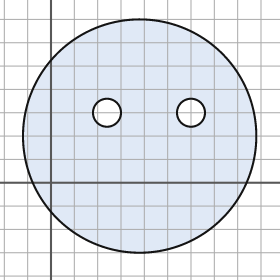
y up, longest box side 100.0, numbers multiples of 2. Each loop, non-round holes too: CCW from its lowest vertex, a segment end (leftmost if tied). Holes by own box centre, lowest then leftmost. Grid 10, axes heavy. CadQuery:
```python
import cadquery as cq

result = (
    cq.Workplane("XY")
    .moveTo(38.0, 20.0)
    .circle(50.0)
    .moveTo(24.0, 30.0)
    .circle(6.0)
    .moveTo(60.0, 30.0)
    .circle(6.0)
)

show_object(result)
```